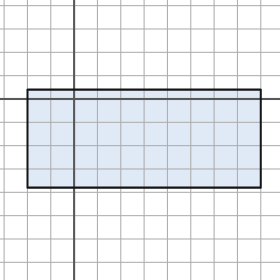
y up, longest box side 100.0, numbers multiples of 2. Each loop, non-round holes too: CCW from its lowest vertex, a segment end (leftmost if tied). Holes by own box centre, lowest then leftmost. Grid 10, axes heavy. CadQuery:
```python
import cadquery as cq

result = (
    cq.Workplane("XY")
    .moveTo(-20.0, -38.0)
    .lineTo(80.0, -38.0)
    .lineTo(80.0, 4.0)
    .lineTo(-20.0, 4.0)
    .close()
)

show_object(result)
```